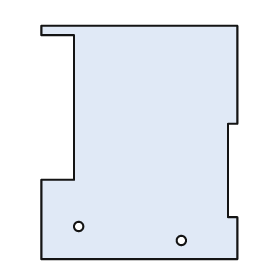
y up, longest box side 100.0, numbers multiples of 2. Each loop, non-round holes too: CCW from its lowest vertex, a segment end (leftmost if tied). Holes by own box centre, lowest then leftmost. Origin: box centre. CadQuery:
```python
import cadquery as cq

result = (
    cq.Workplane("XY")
    .moveTo(-42.0, -50.0)
    .lineTo(42.0, -50.0)
    .lineTo(42.0, -32.0)
    .lineTo(38.0, -32.0)
    .lineTo(38.0, 8.0)
    .lineTo(42.0, 8.0)
    .lineTo(42.0, 50.0)
    .lineTo(-42.0, 50.0)
    .lineTo(-42.0, 46.0)
    .lineTo(-28.0, 46.0)
    .lineTo(-28.0, -16.0)
    .lineTo(-42.0, -16.0)
    .close()
    .moveTo(18.0, -42.0)
    .circle(2.0)
    .moveTo(-26.0, -36.0)
    .circle(2.0)
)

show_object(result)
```